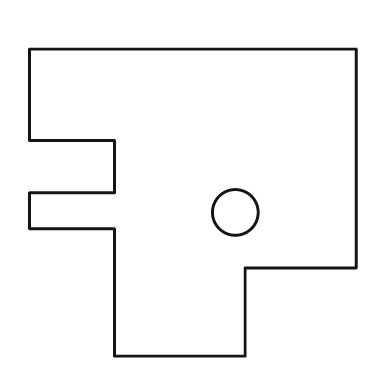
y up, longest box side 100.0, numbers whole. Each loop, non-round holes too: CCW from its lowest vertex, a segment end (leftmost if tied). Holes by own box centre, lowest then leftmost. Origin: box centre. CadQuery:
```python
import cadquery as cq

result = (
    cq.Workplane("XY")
    .moveTo(-24.0, -47.0)
    .lineTo(16.0, -47.0)
    .lineTo(16.0, -20.0)
    .lineTo(50.0, -20.0)
    .lineTo(50.0, 47.0)
    .lineTo(-50.0, 47.0)
    .lineTo(-50.0, 19.0)
    .lineTo(-24.0, 19.0)
    .lineTo(-24.0, 3.0)
    .lineTo(-50.0, 3.0)
    .lineTo(-50.0, -8.0)
    .lineTo(-24.0, -8.0)
    .close()
    .moveTo(13.0, -3.0)
    .circle(7.0)
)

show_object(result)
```